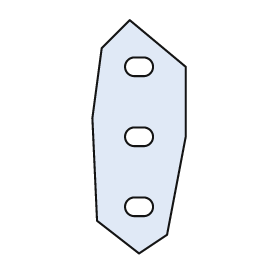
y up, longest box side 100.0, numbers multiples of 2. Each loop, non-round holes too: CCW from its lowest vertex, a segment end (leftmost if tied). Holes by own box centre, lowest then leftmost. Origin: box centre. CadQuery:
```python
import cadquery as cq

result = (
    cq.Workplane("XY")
    .moveTo(0.0, -50.0)
    .lineTo(12.0, -42.0)
    .lineTo(20.0, 0.0)
    .lineTo(20.0, 30.0)
    .lineTo(-4.0, 50.0)
    .lineTo(-16.0, 38.0)
    .lineTo(-20.0, 8.0)
    .lineTo(-18.0, -36.0)
    .close()
    .moveTo(-2.0, -34.0)
    .lineTo(2.0, -34.0)
    .threePointArc((6.0, -30.0), (2.0, -26.0))
    .lineTo(-2.0, -26.0)
    .threePointArc((-6.0, -30.0), (-2.0, -34.0))
    .close()
    .moveTo(-2.0, -4.0)
    .lineTo(2.0, -4.0)
    .threePointArc((6.0, 0.0), (2.0, 4.0))
    .lineTo(-2.0, 4.0)
    .threePointArc((-6.0, 0.0), (-2.0, -4.0))
    .close()
    .moveTo(-2.0, 26.0)
    .lineTo(2.0, 26.0)
    .threePointArc((6.0, 30.0), (2.0, 34.0))
    .lineTo(-2.0, 34.0)
    .threePointArc((-6.0, 30.0), (-2.0, 26.0))
    .close()
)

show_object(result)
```